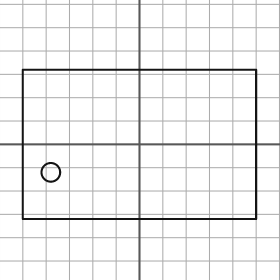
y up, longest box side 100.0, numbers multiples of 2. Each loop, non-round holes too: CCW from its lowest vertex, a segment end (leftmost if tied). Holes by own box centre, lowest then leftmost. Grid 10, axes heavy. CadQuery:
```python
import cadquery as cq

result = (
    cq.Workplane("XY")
    .moveTo(-50.0, -32.0)
    .lineTo(50.0, -32.0)
    .lineTo(50.0, 32.0)
    .lineTo(-50.0, 32.0)
    .close()
    .moveTo(-38.0, -12.0)
    .circle(4.0)
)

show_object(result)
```